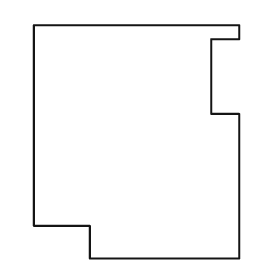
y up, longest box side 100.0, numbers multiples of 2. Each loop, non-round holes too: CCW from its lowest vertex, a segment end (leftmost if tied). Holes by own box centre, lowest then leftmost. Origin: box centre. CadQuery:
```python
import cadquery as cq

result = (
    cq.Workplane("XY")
    .moveTo(-20.0, -50.0)
    .lineTo(44.0, -50.0)
    .lineTo(44.0, 12.0)
    .lineTo(32.0, 12.0)
    .lineTo(32.0, 44.0)
    .lineTo(44.0, 44.0)
    .lineTo(44.0, 50.0)
    .lineTo(-44.0, 50.0)
    .lineTo(-44.0, -36.0)
    .lineTo(-20.0, -36.0)
    .close()
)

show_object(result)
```